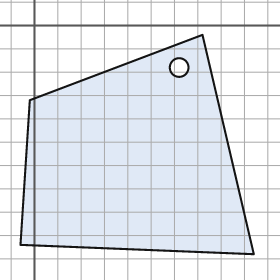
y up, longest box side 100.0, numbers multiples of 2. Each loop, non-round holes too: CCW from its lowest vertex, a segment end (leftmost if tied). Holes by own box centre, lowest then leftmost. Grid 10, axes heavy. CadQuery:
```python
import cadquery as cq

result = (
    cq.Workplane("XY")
    .moveTo(94.0, -98.0)
    .lineTo(72.0, -4.0)
    .lineTo(-2.0, -32.0)
    .lineTo(-6.0, -94.0)
    .close()
    .moveTo(62.0, -18.0)
    .circle(4.0)
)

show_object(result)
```